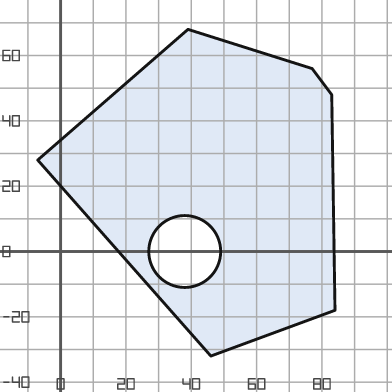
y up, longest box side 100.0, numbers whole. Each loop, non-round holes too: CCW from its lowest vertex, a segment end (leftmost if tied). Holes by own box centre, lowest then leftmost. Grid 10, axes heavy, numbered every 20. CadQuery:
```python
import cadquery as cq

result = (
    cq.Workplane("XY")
    .moveTo(46.0, -32.0)
    .lineTo(84.0, -18.0)
    .lineTo(83.0, 48.0)
    .lineTo(77.0, 56.0)
    .lineTo(39.0, 68.0)
    .lineTo(-7.0, 28.0)
    .close()
    .moveTo(38.0, 0.0)
    .circle(11.0)
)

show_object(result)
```